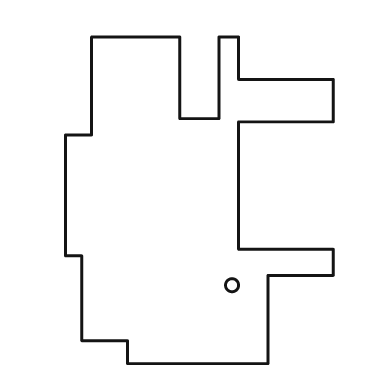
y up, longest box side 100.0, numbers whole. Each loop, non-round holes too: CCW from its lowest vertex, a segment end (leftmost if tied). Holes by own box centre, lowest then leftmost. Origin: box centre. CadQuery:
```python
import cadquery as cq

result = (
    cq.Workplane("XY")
    .moveTo(-22.0, -50.0)
    .lineTo(21.0, -50.0)
    .lineTo(21.0, -23.0)
    .lineTo(41.0, -23.0)
    .lineTo(41.0, -15.0)
    .lineTo(12.0, -15.0)
    .lineTo(12.0, 24.0)
    .lineTo(41.0, 24.0)
    .lineTo(41.0, 37.0)
    .lineTo(12.0, 37.0)
    .lineTo(12.0, 50.0)
    .lineTo(6.0, 50.0)
    .lineTo(6.0, 25.0)
    .lineTo(-6.0, 25.0)
    .lineTo(-6.0, 50.0)
    .lineTo(-33.0, 50.0)
    .lineTo(-33.0, 20.0)
    .lineTo(-41.0, 20.0)
    .lineTo(-41.0, -17.0)
    .lineTo(-36.0, -17.0)
    .lineTo(-36.0, -43.0)
    .lineTo(-22.0, -43.0)
    .close()
    .moveTo(10.0, -26.0)
    .circle(2.0)
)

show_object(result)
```